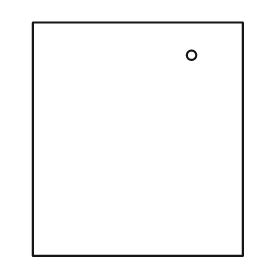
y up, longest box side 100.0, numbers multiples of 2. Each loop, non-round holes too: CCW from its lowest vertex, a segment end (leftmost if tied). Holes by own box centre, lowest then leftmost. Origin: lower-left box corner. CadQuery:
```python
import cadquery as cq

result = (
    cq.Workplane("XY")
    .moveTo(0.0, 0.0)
    .lineTo(90.0, 0.0)
    .lineTo(90.0, 100.0)
    .lineTo(0.0, 100.0)
    .close()
    .moveTo(68.0, 86.0)
    .circle(2.0)
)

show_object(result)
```